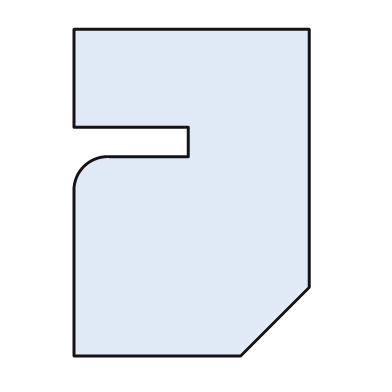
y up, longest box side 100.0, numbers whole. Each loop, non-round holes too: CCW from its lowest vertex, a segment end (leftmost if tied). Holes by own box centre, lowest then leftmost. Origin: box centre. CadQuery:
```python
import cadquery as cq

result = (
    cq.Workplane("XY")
    .moveTo(-36.0, -50.0)
    .lineTo(15.0, -50.0)
    .lineTo(36.0, -29.0)
    .lineTo(36.0, 50.0)
    .lineTo(-36.0, 50.0)
    .lineTo(-36.0, 20.0)
    .lineTo(-1.0, 20.0)
    .lineTo(-1.0, 11.0)
    .lineTo(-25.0, 11.0)
    .threePointArc((-33.0, 8.0), (-36.0, 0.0))
    .close()
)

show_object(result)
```